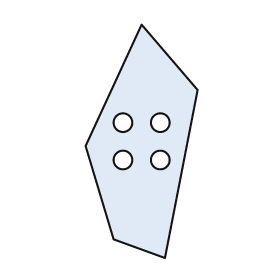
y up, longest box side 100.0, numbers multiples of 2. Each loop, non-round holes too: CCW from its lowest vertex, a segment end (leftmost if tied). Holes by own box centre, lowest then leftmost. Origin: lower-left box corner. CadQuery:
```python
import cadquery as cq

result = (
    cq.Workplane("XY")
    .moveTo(34.0, 0.0)
    .lineTo(48.0, 72.0)
    .lineTo(24.0, 100.0)
    .lineTo(0.0, 48.0)
    .lineTo(12.0, 8.0)
    .close()
    .moveTo(16.0, 42.0)
    .circle(4.0)
    .moveTo(32.0, 42.0)
    .circle(4.0)
    .moveTo(16.0, 58.0)
    .circle(4.0)
    .moveTo(32.0, 58.0)
    .circle(4.0)
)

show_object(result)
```